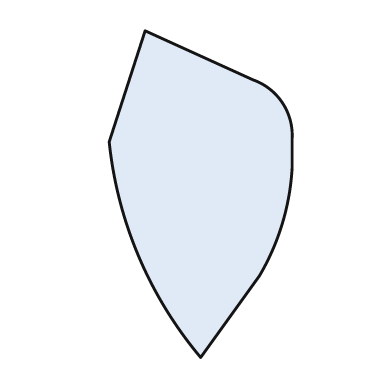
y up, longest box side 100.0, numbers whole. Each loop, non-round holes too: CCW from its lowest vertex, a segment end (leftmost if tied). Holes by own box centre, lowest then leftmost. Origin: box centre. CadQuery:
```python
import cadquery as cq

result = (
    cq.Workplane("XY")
    .moveTo(0.0, -50.0)
    .lineTo(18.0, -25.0)
    .threePointArc((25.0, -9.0), (28.0, 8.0))
    .lineTo(28.0, 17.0)
    .threePointArc((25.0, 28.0), (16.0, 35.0))
    .lineTo(-17.0, 50.0)
    .lineTo(-28.0, 16.0)
    .threePointArc((-19.0, -19.0), (0.0, -50.0))
    .close()
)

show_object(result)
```